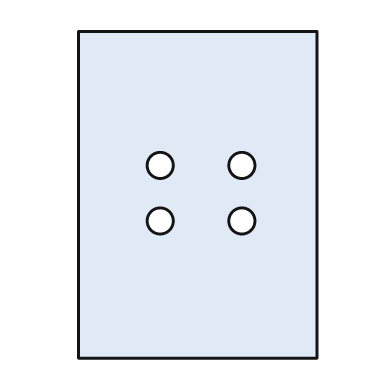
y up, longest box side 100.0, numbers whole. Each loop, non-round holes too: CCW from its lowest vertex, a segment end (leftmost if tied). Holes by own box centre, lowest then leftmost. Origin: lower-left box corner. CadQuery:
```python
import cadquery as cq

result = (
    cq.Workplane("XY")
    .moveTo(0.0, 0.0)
    .lineTo(73.0, 0.0)
    .lineTo(73.0, 100.0)
    .lineTo(0.0, 100.0)
    .close()
    .moveTo(25.0, 42.0)
    .circle(4.0)
    .moveTo(50.0, 42.0)
    .circle(4.0)
    .moveTo(25.0, 59.0)
    .circle(4.0)
    .moveTo(50.0, 59.0)
    .circle(4.0)
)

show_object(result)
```